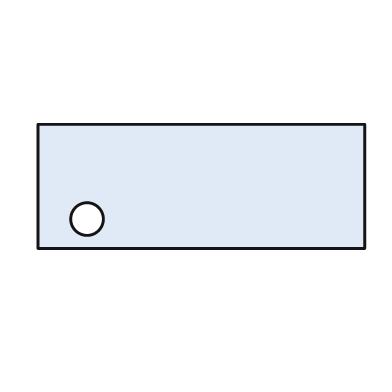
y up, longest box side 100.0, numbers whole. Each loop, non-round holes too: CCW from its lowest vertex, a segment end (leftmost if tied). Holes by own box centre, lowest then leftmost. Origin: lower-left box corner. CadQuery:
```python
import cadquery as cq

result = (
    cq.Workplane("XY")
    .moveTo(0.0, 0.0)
    .lineTo(100.0, 0.0)
    .lineTo(100.0, 38.0)
    .lineTo(0.0, 38.0)
    .close()
    .moveTo(15.0, 9.0)
    .circle(5.0)
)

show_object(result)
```